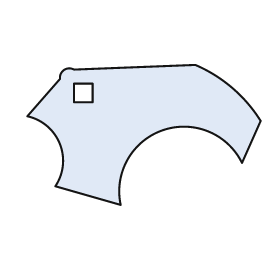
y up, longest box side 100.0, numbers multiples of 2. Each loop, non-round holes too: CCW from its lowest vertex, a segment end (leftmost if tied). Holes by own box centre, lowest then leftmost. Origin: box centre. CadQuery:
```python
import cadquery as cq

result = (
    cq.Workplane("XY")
    .moveTo(-10.0, -30.0)
    .threePointArc((8.0, 2.0), (42.0, -12.0))
    .lineTo(50.0, 6.0)
    .threePointArc((38.0, 20.0), (22.0, 30.0))
    .lineTo(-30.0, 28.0)
    .threePointArc((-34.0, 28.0), (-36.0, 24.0))
    .lineTo(-50.0, 8.0)
    .threePointArc((-36.0, -4.0), (-38.0, -22.0))
    .close()
    .moveTo(-30.0, 14.0)
    .lineTo(-22.0, 14.0)
    .lineTo(-22.0, 22.0)
    .lineTo(-30.0, 22.0)
    .close()
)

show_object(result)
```